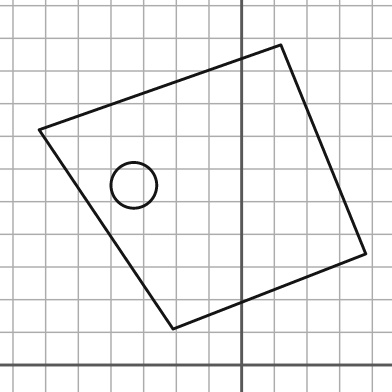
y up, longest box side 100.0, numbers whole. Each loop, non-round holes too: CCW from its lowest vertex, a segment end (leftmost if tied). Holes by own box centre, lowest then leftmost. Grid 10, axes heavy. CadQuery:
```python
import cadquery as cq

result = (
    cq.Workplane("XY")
    .moveTo(-21.0, 11.0)
    .lineTo(38.0, 34.0)
    .lineTo(12.0, 98.0)
    .lineTo(-62.0, 72.0)
    .close()
    .moveTo(-33.0, 55.0)
    .circle(7.0)
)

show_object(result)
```